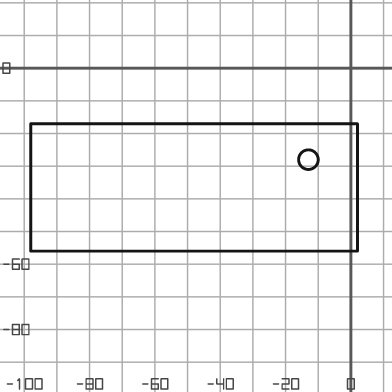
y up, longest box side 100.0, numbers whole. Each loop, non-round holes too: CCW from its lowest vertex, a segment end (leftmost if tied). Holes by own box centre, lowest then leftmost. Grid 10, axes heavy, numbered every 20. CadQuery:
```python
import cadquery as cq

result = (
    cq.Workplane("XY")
    .moveTo(-98.0, -56.0)
    .lineTo(2.0, -56.0)
    .lineTo(2.0, -17.0)
    .lineTo(-98.0, -17.0)
    .close()
    .moveTo(-13.0, -28.0)
    .circle(3.0)
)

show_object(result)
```